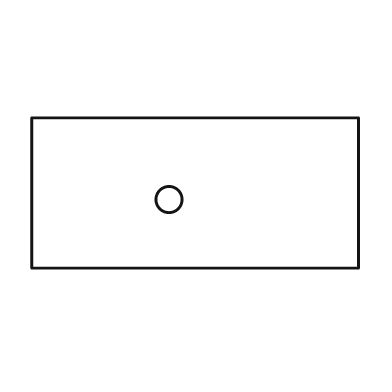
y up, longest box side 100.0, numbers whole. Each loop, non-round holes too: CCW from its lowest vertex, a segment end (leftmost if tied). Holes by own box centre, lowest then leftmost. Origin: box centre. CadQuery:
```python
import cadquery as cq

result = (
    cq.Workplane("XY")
    .moveTo(-50.0, -23.0)
    .lineTo(50.0, -23.0)
    .lineTo(50.0, 23.0)
    .lineTo(-50.0, 23.0)
    .close()
    .moveTo(-8.0, -2.0)
    .circle(4.0)
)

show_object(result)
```